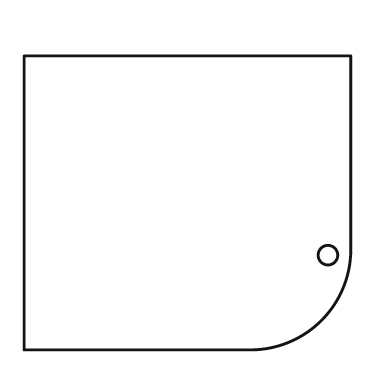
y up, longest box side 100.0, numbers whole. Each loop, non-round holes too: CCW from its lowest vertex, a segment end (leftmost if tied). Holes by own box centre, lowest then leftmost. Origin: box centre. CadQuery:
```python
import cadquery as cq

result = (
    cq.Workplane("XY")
    .moveTo(-50.0, -45.0)
    .lineTo(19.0, -45.0)
    .threePointArc((41.0, -36.0), (50.0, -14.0))
    .lineTo(50.0, 45.0)
    .lineTo(-50.0, 45.0)
    .close()
    .moveTo(43.0, -16.0)
    .circle(3.0)
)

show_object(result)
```